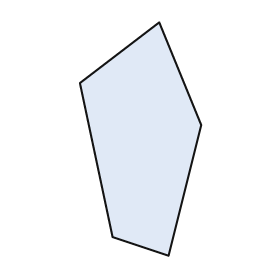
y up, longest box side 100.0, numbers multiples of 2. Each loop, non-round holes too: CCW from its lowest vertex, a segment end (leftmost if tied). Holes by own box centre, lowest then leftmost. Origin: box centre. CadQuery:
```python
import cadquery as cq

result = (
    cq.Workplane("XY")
    .moveTo(12.0, -50.0)
    .lineTo(26.0, 6.0)
    .lineTo(8.0, 50.0)
    .lineTo(-26.0, 24.0)
    .lineTo(-12.0, -42.0)
    .close()
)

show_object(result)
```